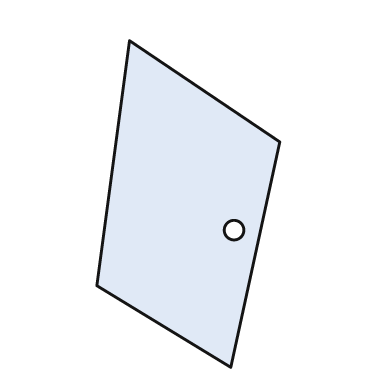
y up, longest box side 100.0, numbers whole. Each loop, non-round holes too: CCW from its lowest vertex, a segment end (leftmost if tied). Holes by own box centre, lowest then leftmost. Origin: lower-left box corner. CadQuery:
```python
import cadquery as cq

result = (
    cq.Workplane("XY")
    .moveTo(41.0, 0.0)
    .lineTo(56.0, 69.0)
    .lineTo(10.0, 100.0)
    .lineTo(0.0, 25.0)
    .close()
    .moveTo(42.0, 42.0)
    .circle(3.0)
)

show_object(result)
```